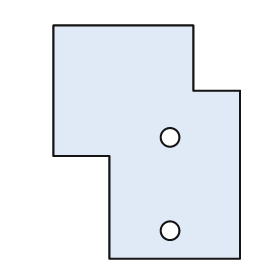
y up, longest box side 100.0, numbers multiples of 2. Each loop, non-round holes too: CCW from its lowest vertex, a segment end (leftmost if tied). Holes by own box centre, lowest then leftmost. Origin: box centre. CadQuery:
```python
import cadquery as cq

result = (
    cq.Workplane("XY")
    .moveTo(-16.0, -50.0)
    .lineTo(40.0, -50.0)
    .lineTo(40.0, 22.0)
    .lineTo(20.0, 22.0)
    .lineTo(20.0, 50.0)
    .lineTo(-40.0, 50.0)
    .lineTo(-40.0, -6.0)
    .lineTo(-16.0, -6.0)
    .close()
    .moveTo(10.0, -38.0)
    .circle(4.0)
    .moveTo(10.0, 2.0)
    .circle(4.0)
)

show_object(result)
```